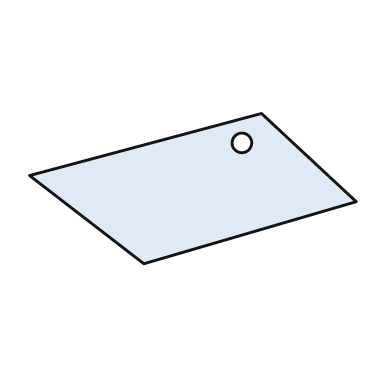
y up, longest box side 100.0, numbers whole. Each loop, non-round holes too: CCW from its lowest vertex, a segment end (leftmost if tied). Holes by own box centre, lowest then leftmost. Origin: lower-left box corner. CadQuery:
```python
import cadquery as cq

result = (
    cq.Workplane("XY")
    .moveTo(35.0, 0.0)
    .lineTo(100.0, 19.0)
    .lineTo(71.0, 46.0)
    .lineTo(0.0, 27.0)
    .close()
    .moveTo(65.0, 37.0)
    .circle(3.0)
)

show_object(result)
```